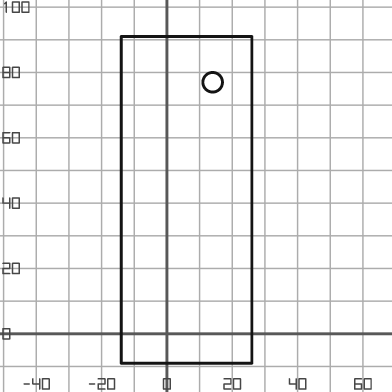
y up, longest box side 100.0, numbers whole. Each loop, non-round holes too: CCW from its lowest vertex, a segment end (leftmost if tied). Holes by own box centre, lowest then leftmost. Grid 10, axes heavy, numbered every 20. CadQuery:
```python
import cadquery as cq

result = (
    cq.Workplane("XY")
    .moveTo(-14.0, -9.0)
    .lineTo(26.0, -9.0)
    .lineTo(26.0, 91.0)
    .lineTo(-14.0, 91.0)
    .close()
    .moveTo(14.0, 77.0)
    .circle(3.0)
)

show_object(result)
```